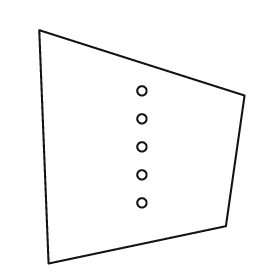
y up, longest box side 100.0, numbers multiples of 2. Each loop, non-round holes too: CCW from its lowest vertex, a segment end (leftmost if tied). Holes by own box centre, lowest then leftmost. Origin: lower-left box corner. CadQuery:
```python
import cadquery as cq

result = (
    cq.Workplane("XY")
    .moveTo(4.0, 0.0)
    .lineTo(80.0, 16.0)
    .lineTo(88.0, 72.0)
    .lineTo(0.0, 100.0)
    .close()
    .moveTo(44.0, 26.0)
    .circle(2.0)
    .moveTo(44.0, 38.0)
    .circle(2.0)
    .moveTo(44.0, 50.0)
    .circle(2.0)
    .moveTo(44.0, 62.0)
    .circle(2.0)
    .moveTo(44.0, 74.0)
    .circle(2.0)
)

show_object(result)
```